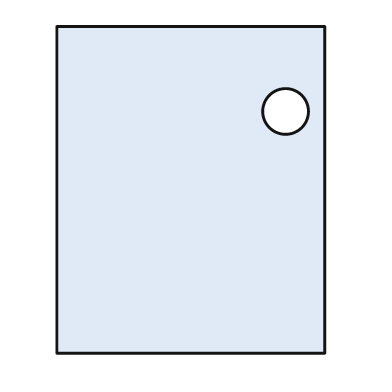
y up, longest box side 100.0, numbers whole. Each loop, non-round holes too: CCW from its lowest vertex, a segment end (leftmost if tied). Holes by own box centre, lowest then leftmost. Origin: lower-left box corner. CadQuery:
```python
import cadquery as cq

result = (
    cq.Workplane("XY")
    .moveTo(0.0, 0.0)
    .lineTo(82.0, 0.0)
    .lineTo(82.0, 100.0)
    .lineTo(0.0, 100.0)
    .close()
    .moveTo(70.0, 74.0)
    .circle(7.0)
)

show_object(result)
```